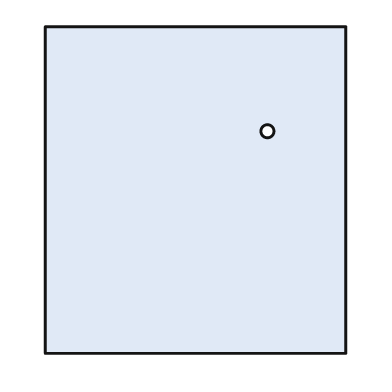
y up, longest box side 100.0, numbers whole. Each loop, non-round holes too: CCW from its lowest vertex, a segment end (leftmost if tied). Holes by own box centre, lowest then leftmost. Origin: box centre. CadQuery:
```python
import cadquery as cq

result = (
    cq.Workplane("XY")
    .moveTo(-46.0, -50.0)
    .lineTo(46.0, -50.0)
    .lineTo(46.0, 50.0)
    .lineTo(-46.0, 50.0)
    .close()
    .moveTo(22.0, 18.0)
    .circle(2.0)
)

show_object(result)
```